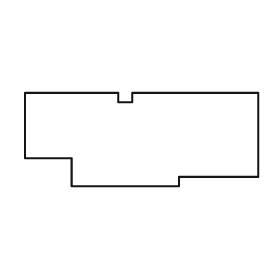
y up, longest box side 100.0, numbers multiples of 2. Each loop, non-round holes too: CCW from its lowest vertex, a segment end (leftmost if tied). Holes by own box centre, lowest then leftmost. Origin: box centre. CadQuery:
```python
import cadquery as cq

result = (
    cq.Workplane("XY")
    .moveTo(-30.0, -20.0)
    .lineTo(16.0, -20.0)
    .lineTo(16.0, -16.0)
    .lineTo(50.0, -16.0)
    .lineTo(50.0, 20.0)
    .lineTo(-4.0, 20.0)
    .lineTo(-4.0, 16.0)
    .lineTo(-10.0, 16.0)
    .lineTo(-10.0, 20.0)
    .lineTo(-50.0, 20.0)
    .lineTo(-50.0, -8.0)
    .lineTo(-30.0, -8.0)
    .close()
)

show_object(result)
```